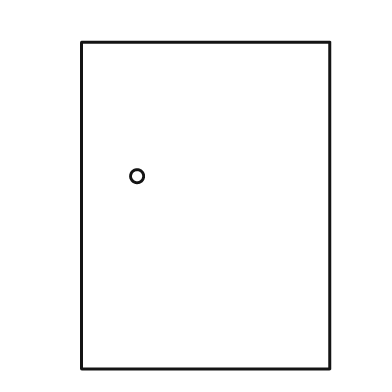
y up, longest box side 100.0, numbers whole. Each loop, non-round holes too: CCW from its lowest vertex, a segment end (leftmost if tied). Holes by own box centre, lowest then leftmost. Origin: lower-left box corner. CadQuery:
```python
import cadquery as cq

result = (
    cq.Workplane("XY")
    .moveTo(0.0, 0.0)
    .lineTo(76.0, 0.0)
    .lineTo(76.0, 100.0)
    .lineTo(0.0, 100.0)
    .close()
    .moveTo(17.0, 59.0)
    .circle(2.0)
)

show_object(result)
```